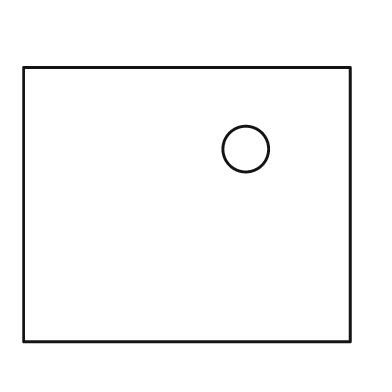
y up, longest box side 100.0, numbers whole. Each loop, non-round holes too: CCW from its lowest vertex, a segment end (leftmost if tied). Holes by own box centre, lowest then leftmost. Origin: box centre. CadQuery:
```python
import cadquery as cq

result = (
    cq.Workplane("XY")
    .moveTo(-50.0, -42.0)
    .lineTo(50.0, -42.0)
    .lineTo(50.0, 42.0)
    .lineTo(-50.0, 42.0)
    .close()
    .moveTo(18.0, 17.0)
    .circle(7.0)
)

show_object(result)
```